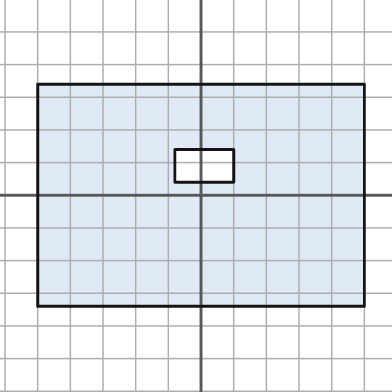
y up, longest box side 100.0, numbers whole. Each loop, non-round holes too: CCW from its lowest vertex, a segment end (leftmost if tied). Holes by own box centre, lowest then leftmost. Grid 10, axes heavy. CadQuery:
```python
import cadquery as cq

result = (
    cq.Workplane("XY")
    .moveTo(-50.0, -34.0)
    .lineTo(50.0, -34.0)
    .lineTo(50.0, 34.0)
    .lineTo(-50.0, 34.0)
    .close()
    .moveTo(-8.0, 4.0)
    .lineTo(10.0, 4.0)
    .lineTo(10.0, 14.0)
    .lineTo(-8.0, 14.0)
    .close()
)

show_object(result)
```